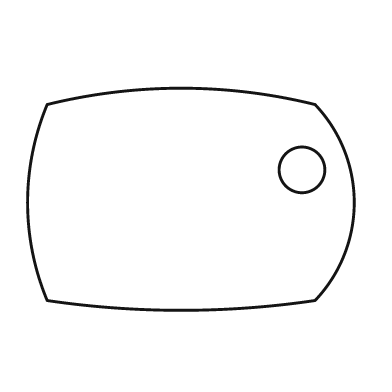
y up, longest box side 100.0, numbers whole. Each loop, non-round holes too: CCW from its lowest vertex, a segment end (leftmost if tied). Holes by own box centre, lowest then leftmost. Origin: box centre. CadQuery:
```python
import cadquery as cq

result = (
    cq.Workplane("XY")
    .moveTo(-44.0, -31.0)
    .threePointArc((-3.0, -34.0), (38.0, -31.0))
    .threePointArc((50.0, -1.0), (38.0, 29.0))
    .threePointArc((-3.0, 34.0), (-44.0, 29.0))
    .threePointArc((-50.0, -1.0), (-44.0, -31.0))
    .close()
    .moveTo(34.0, 9.0)
    .circle(7.0)
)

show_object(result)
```